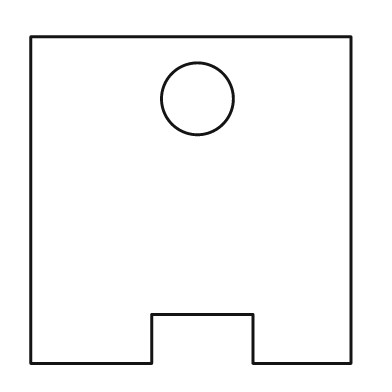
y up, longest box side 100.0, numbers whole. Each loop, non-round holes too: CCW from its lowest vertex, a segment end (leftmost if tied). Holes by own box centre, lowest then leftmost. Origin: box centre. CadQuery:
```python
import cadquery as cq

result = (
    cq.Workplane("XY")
    .moveTo(-49.0, -50.0)
    .lineTo(-12.0, -50.0)
    .lineTo(-12.0, -35.0)
    .lineTo(19.0, -35.0)
    .lineTo(19.0, -50.0)
    .lineTo(49.0, -50.0)
    .lineTo(49.0, 50.0)
    .lineTo(-49.0, 50.0)
    .close()
    .moveTo(2.0, 31.0)
    .circle(11.0)
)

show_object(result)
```